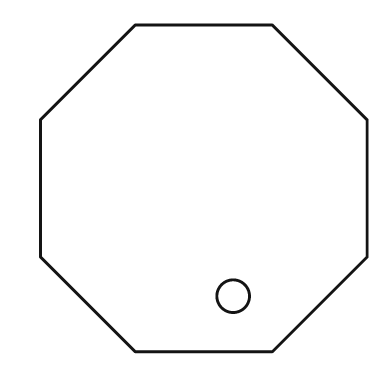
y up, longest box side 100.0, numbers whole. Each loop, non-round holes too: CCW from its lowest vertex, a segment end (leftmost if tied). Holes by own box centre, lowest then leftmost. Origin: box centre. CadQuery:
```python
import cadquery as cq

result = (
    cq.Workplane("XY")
    .moveTo(-21.0, -50.0)
    .lineTo(21.0, -50.0)
    .lineTo(50.0, -21.0)
    .lineTo(50.0, 21.0)
    .lineTo(21.0, 50.0)
    .lineTo(-21.0, 50.0)
    .lineTo(-50.0, 21.0)
    .lineTo(-50.0, -21.0)
    .close()
    .moveTo(9.0, -33.0)
    .circle(5.0)
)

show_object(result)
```